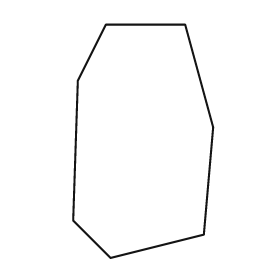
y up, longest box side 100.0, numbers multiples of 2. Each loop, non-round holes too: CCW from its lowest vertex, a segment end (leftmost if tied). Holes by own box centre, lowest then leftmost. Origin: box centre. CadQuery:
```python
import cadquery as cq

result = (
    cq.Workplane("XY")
    .moveTo(-14.0, -50.0)
    .lineTo(26.0, -40.0)
    .lineTo(30.0, 6.0)
    .lineTo(18.0, 50.0)
    .lineTo(-16.0, 50.0)
    .lineTo(-28.0, 26.0)
    .lineTo(-30.0, -34.0)
    .close()
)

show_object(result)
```